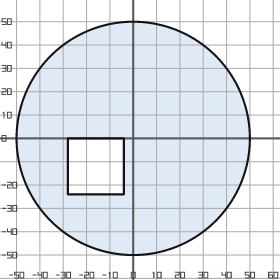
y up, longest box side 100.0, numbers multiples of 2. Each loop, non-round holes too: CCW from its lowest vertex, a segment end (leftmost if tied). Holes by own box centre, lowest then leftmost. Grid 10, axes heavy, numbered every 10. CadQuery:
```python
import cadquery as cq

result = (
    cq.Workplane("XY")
    .moveTo(0.0, 0.0)
    .circle(50.0)
    .moveTo(-28.0, -24.0)
    .lineTo(-4.0, -24.0)
    .lineTo(-4.0, 0.0)
    .lineTo(-28.0, 0.0)
    .close()
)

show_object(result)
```